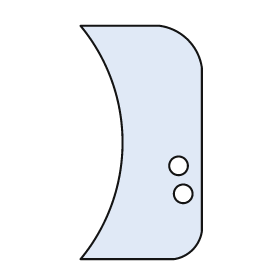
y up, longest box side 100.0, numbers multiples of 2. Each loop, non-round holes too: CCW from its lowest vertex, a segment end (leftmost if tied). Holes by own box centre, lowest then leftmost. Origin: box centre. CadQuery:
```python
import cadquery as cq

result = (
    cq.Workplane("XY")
    .moveTo(-26.0, -50.0)
    .lineTo(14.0, -50.0)
    .threePointArc((22.0, -46.0), (26.0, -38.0))
    .lineTo(26.0, 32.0)
    .threePointArc((20.0, 44.0), (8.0, 50.0))
    .lineTo(-26.0, 50.0)
    .threePointArc((-8.0, 0.0), (-26.0, -50.0))
    .close()
    .moveTo(18.0, -22.0)
    .circle(4.0)
    .moveTo(16.0, -10.0)
    .circle(4.0)
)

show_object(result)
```